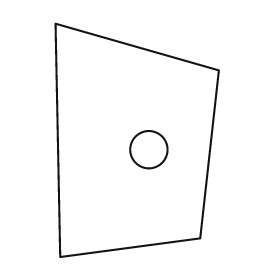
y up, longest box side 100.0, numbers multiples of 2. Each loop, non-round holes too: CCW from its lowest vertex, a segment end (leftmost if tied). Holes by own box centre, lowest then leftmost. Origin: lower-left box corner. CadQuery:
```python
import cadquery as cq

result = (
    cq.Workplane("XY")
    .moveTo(2.0, 0.0)
    .lineTo(62.0, 8.0)
    .lineTo(70.0, 80.0)
    .lineTo(0.0, 100.0)
    .close()
    .moveTo(40.0, 46.0)
    .circle(8.0)
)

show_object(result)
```